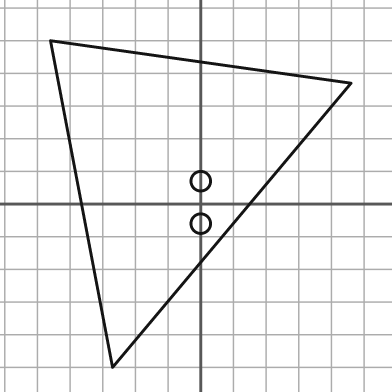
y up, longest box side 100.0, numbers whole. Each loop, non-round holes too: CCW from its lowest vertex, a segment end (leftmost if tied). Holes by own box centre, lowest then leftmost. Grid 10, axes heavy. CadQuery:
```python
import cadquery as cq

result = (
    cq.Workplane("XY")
    .moveTo(-27.0, -50.0)
    .lineTo(46.0, 37.0)
    .lineTo(-46.0, 50.0)
    .close()
    .moveTo(0.0, -6.0)
    .circle(3.0)
    .moveTo(0.0, 7.0)
    .circle(3.0)
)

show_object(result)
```